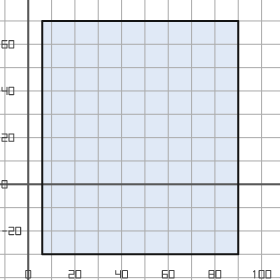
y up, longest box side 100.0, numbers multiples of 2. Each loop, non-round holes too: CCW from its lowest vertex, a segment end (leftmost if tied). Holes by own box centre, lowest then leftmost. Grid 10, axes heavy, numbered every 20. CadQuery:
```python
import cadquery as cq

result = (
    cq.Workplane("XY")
    .moveTo(6.0, -30.0)
    .lineTo(90.0, -30.0)
    .lineTo(90.0, 70.0)
    .lineTo(6.0, 70.0)
    .close()
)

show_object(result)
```